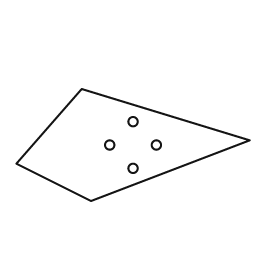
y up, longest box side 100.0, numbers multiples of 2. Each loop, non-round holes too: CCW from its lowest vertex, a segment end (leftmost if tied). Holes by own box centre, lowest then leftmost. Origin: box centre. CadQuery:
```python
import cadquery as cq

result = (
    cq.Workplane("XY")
    .moveTo(-18.0, -24.0)
    .lineTo(50.0, 2.0)
    .lineTo(-22.0, 24.0)
    .lineTo(-50.0, -8.0)
    .close()
    .moveTo(0.0, -10.0)
    .circle(2.0)
    .moveTo(-10.0, 0.0)
    .circle(2.0)
    .moveTo(10.0, 0.0)
    .circle(2.0)
    .moveTo(0.0, 10.0)
    .circle(2.0)
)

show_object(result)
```